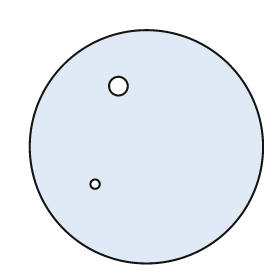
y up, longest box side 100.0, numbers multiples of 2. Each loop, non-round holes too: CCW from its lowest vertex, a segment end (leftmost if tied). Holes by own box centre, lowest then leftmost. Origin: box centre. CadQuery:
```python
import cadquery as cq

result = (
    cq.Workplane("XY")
    .moveTo(0.0, 0.0)
    .circle(50.0)
    .moveTo(-22.0, -16.0)
    .circle(2.0)
    .moveTo(-12.0, 26.0)
    .circle(4.0)
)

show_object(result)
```